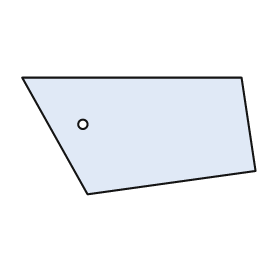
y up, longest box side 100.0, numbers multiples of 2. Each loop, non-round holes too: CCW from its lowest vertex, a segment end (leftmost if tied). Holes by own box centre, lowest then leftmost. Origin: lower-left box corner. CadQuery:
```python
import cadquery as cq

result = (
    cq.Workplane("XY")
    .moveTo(28.0, 0.0)
    .lineTo(100.0, 10.0)
    .lineTo(94.0, 50.0)
    .lineTo(0.0, 50.0)
    .close()
    .moveTo(26.0, 30.0)
    .circle(2.0)
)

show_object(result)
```